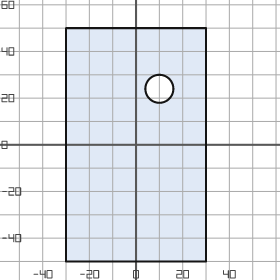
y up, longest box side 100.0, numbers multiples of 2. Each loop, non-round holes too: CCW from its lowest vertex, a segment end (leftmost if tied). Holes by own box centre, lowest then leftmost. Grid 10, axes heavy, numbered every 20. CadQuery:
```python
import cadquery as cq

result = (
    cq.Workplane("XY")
    .moveTo(-30.0, -50.0)
    .lineTo(30.0, -50.0)
    .lineTo(30.0, 50.0)
    .lineTo(-30.0, 50.0)
    .close()
    .moveTo(10.0, 24.0)
    .circle(6.0)
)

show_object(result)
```